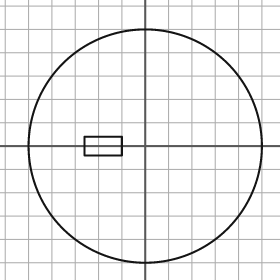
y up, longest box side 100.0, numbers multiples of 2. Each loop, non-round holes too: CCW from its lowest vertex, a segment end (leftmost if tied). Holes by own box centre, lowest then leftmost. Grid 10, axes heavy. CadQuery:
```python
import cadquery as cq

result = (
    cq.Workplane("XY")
    .moveTo(0.0, 0.0)
    .circle(50.0)
    .moveTo(-26.0, -4.0)
    .lineTo(-10.0, -4.0)
    .lineTo(-10.0, 4.0)
    .lineTo(-26.0, 4.0)
    .close()
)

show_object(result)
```